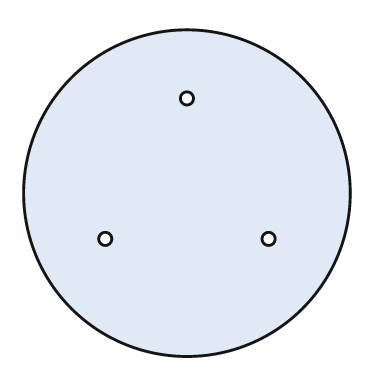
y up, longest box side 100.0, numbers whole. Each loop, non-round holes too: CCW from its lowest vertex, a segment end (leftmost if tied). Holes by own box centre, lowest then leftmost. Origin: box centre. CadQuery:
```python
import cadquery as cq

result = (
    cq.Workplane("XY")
    .moveTo(0.0, 0.0)
    .circle(50.0)
    .moveTo(-25.0, -14.0)
    .circle(2.0)
    .moveTo(25.0, -14.0)
    .circle(2.0)
    .moveTo(0.0, 29.0)
    .circle(2.0)
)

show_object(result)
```